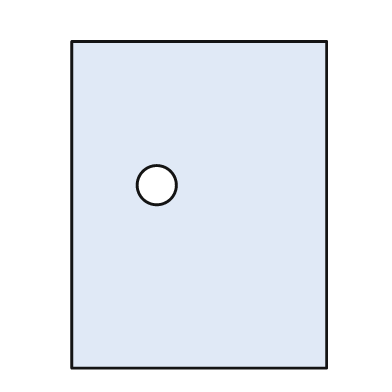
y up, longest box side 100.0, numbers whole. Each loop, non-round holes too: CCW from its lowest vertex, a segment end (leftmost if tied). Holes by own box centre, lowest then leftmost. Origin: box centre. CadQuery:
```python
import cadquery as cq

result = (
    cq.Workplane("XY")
    .moveTo(-39.0, -50.0)
    .lineTo(39.0, -50.0)
    .lineTo(39.0, 50.0)
    .lineTo(-39.0, 50.0)
    .close()
    .moveTo(-13.0, 6.0)
    .circle(6.0)
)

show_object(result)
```